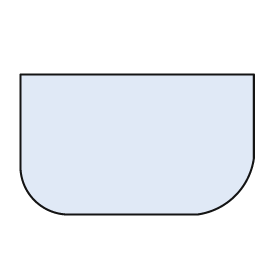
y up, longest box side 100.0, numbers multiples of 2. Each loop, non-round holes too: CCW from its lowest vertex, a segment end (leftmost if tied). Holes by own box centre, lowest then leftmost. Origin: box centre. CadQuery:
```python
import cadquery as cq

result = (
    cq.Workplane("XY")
    .moveTo(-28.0, -30.0)
    .lineTo(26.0, -30.0)
    .threePointArc((42.0, -22.0), (50.0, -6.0))
    .lineTo(50.0, 30.0)
    .lineTo(-50.0, 30.0)
    .lineTo(-50.0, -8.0)
    .threePointArc((-44.0, -24.0), (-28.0, -30.0))
    .close()
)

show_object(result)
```